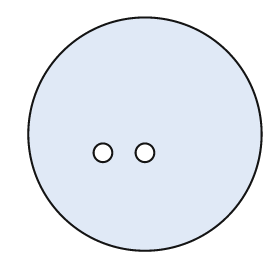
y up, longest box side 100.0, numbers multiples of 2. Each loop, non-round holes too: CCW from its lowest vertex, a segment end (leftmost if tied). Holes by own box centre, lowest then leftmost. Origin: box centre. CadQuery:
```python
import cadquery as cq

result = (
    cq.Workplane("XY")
    .moveTo(0.0, 0.0)
    .circle(50.0)
    .moveTo(-18.0, -8.0)
    .circle(4.0)
    .moveTo(0.0, -8.0)
    .circle(4.0)
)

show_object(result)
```